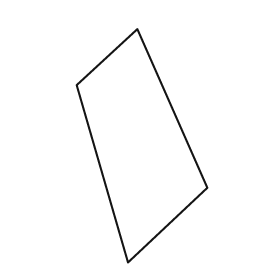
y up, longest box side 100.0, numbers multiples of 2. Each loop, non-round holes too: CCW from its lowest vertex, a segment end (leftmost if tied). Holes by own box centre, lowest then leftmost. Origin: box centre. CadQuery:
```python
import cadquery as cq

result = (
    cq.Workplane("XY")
    .moveTo(-6.0, -50.0)
    .lineTo(28.0, -18.0)
    .lineTo(-2.0, 50.0)
    .lineTo(-28.0, 26.0)
    .close()
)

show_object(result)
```